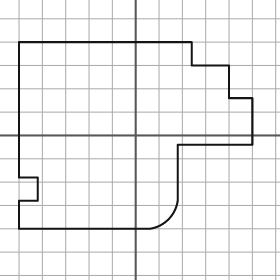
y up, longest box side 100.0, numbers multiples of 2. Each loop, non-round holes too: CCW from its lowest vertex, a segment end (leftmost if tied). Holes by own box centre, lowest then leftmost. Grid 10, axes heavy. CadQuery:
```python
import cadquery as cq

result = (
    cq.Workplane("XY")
    .moveTo(-50.0, -40.0)
    .lineTo(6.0, -40.0)
    .threePointArc((14.0, -36.0), (18.0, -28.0))
    .lineTo(18.0, -4.0)
    .lineTo(50.0, -4.0)
    .lineTo(50.0, 16.0)
    .lineTo(40.0, 16.0)
    .lineTo(40.0, 30.0)
    .lineTo(24.0, 30.0)
    .lineTo(24.0, 40.0)
    .lineTo(-50.0, 40.0)
    .lineTo(-50.0, -18.0)
    .lineTo(-42.0, -18.0)
    .lineTo(-42.0, -28.0)
    .lineTo(-50.0, -28.0)
    .close()
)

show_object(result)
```